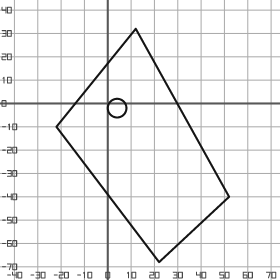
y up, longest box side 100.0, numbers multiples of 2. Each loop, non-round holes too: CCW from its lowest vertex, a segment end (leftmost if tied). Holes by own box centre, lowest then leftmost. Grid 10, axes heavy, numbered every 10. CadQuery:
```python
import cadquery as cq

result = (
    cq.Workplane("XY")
    .moveTo(22.0, -68.0)
    .lineTo(52.0, -40.0)
    .lineTo(12.0, 32.0)
    .lineTo(-22.0, -10.0)
    .close()
    .moveTo(4.0, -2.0)
    .circle(4.0)
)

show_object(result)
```